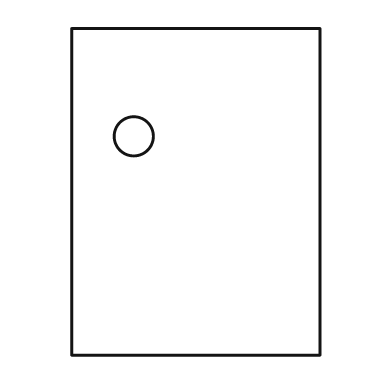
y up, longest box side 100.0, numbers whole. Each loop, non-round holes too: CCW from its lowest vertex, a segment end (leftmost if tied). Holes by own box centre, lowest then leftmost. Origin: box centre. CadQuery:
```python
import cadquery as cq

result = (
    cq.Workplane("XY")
    .moveTo(-38.0, -50.0)
    .lineTo(38.0, -50.0)
    .lineTo(38.0, 50.0)
    .lineTo(-38.0, 50.0)
    .close()
    .moveTo(-19.0, 17.0)
    .circle(6.0)
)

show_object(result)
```